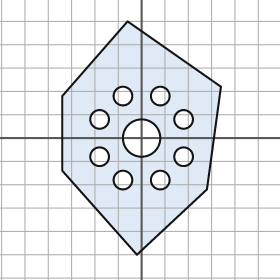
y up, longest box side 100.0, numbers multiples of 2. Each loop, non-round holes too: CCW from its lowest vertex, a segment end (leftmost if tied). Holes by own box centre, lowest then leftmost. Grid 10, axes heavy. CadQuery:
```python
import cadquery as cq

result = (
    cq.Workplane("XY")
    .moveTo(-2.0, -50.0)
    .lineTo(28.0, -22.0)
    .lineTo(34.0, 22.0)
    .lineTo(-6.0, 50.0)
    .lineTo(-34.0, 18.0)
    .lineTo(-34.0, -14.0)
    .close()
    .moveTo(-8.0, -18.0)
    .circle(4.0)
    .moveTo(8.0, -18.0)
    .circle(4.0)
    .moveTo(-18.0, -8.0)
    .circle(4.0)
    .moveTo(18.0, -8.0)
    .circle(4.0)
    .moveTo(0.0, 0.0)
    .circle(8.0)
    .moveTo(-18.0, 8.0)
    .circle(4.0)
    .moveTo(18.0, 8.0)
    .circle(4.0)
    .moveTo(-8.0, 18.0)
    .circle(4.0)
    .moveTo(8.0, 18.0)
    .circle(4.0)
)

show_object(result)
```